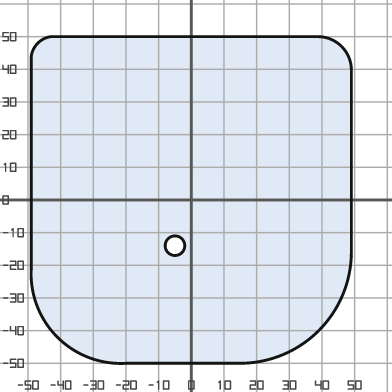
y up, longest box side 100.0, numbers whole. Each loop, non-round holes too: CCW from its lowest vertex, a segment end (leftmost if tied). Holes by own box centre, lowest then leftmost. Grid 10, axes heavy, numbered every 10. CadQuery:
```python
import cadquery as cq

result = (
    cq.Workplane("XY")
    .moveTo(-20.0, -50.0)
    .lineTo(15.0, -50.0)
    .threePointArc((39.0, -40.0), (49.0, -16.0))
    .lineTo(49.0, 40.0)
    .threePointArc((46.0, 47.0), (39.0, 50.0))
    .lineTo(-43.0, 50.0)
    .threePointArc((-47.0, 48.0), (-49.0, 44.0))
    .lineTo(-49.0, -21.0)
    .threePointArc((-41.0, -42.0), (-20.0, -50.0))
    .close()
    .moveTo(-5.0, -14.0)
    .circle(3.0)
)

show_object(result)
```